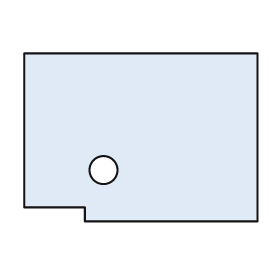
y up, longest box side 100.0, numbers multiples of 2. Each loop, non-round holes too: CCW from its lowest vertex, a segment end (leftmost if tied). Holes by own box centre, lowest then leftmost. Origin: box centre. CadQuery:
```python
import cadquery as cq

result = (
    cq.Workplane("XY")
    .moveTo(-24.0, -36.0)
    .lineTo(50.0, -36.0)
    .lineTo(50.0, 36.0)
    .lineTo(-50.0, 36.0)
    .lineTo(-50.0, -30.0)
    .lineTo(-24.0, -30.0)
    .close()
    .moveTo(-16.0, -14.0)
    .circle(6.0)
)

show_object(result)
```